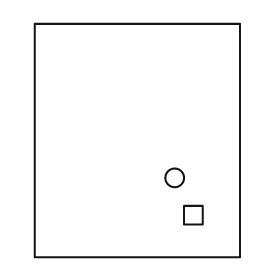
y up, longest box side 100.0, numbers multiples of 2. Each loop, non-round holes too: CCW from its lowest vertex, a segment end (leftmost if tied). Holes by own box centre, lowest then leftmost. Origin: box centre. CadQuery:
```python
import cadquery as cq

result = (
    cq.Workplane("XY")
    .moveTo(-44.0, -50.0)
    .lineTo(44.0, -50.0)
    .lineTo(44.0, 50.0)
    .lineTo(-44.0, 50.0)
    .close()
    .moveTo(20.0, -36.0)
    .lineTo(28.0, -36.0)
    .lineTo(28.0, -28.0)
    .lineTo(20.0, -28.0)
    .close()
    .moveTo(16.0, -16.0)
    .circle(4.0)
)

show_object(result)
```